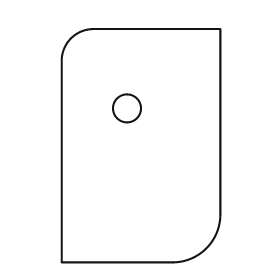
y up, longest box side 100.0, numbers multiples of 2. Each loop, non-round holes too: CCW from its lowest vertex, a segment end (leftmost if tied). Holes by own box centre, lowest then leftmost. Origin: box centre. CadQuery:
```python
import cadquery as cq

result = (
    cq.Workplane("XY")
    .moveTo(-34.0, -50.0)
    .lineTo(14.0, -50.0)
    .threePointArc((28.0, -44.0), (34.0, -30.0))
    .lineTo(34.0, 50.0)
    .lineTo(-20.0, 50.0)
    .threePointArc((-30.0, 46.0), (-34.0, 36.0))
    .close()
    .moveTo(-6.0, 16.0)
    .circle(6.0)
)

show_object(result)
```